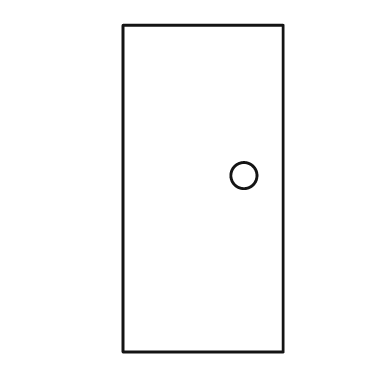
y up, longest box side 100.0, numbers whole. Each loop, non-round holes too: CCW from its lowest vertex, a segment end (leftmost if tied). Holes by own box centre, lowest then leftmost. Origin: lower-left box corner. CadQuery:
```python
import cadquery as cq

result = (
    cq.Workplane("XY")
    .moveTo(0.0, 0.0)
    .lineTo(49.0, 0.0)
    .lineTo(49.0, 100.0)
    .lineTo(0.0, 100.0)
    .close()
    .moveTo(37.0, 54.0)
    .circle(4.0)
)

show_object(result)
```